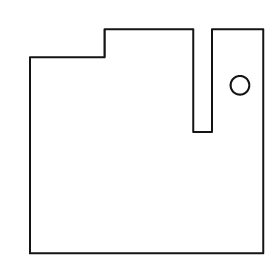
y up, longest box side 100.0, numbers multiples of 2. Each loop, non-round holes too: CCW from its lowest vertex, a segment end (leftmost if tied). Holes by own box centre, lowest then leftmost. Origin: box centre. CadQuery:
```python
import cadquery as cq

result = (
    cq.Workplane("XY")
    .moveTo(-50.0, -48.0)
    .lineTo(50.0, -48.0)
    .lineTo(50.0, 48.0)
    .lineTo(28.0, 48.0)
    .lineTo(28.0, 4.0)
    .lineTo(20.0, 4.0)
    .lineTo(20.0, 48.0)
    .lineTo(-18.0, 48.0)
    .lineTo(-18.0, 36.0)
    .lineTo(-50.0, 36.0)
    .close()
    .moveTo(40.0, 24.0)
    .circle(4.0)
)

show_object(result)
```